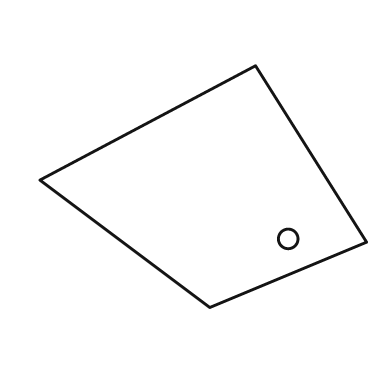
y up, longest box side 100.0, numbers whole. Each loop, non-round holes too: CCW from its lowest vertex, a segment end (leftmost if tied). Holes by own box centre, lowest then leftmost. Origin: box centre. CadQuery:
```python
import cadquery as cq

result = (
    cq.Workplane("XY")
    .moveTo(2.0, -37.0)
    .lineTo(50.0, -17.0)
    .lineTo(16.0, 37.0)
    .lineTo(-50.0, 2.0)
    .close()
    .moveTo(26.0, -16.0)
    .circle(3.0)
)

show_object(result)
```